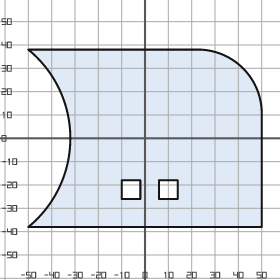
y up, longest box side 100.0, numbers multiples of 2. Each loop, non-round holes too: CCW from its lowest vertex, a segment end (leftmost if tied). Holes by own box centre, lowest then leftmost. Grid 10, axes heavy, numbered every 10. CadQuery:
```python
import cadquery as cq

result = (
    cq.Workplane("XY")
    .moveTo(-50.0, -38.0)
    .lineTo(50.0, -38.0)
    .lineTo(50.0, 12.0)
    .threePointArc((42.0, 30.0), (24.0, 38.0))
    .lineTo(-50.0, 38.0)
    .threePointArc((-32.0, 0.0), (-50.0, -38.0))
    .close()
    .moveTo(-10.0, -26.0)
    .lineTo(-2.0, -26.0)
    .lineTo(-2.0, -18.0)
    .lineTo(-10.0, -18.0)
    .close()
    .moveTo(6.0, -26.0)
    .lineTo(14.0, -26.0)
    .lineTo(14.0, -18.0)
    .lineTo(6.0, -18.0)
    .close()
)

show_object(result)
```